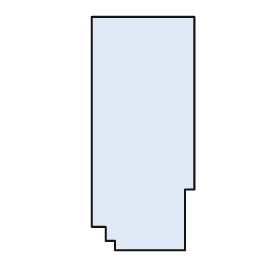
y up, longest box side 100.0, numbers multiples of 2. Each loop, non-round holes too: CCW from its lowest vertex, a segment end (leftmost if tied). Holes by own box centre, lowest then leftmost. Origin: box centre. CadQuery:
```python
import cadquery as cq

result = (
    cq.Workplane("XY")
    .moveTo(-12.0, -50.0)
    .lineTo(18.0, -50.0)
    .lineTo(18.0, -24.0)
    .lineTo(22.0, -24.0)
    .lineTo(22.0, 50.0)
    .lineTo(-22.0, 50.0)
    .lineTo(-22.0, -40.0)
    .lineTo(-16.0, -40.0)
    .lineTo(-16.0, -46.0)
    .lineTo(-12.0, -46.0)
    .close()
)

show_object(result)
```